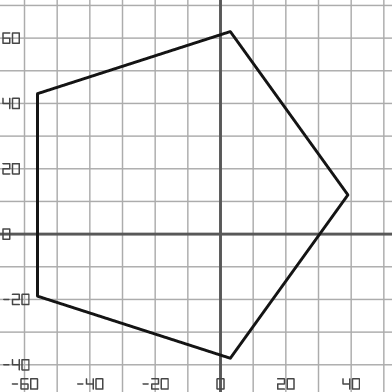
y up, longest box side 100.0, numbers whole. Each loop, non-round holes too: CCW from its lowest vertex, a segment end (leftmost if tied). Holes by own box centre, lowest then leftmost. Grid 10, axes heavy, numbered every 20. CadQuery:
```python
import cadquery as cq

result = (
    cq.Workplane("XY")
    .moveTo(3.0, -38.0)
    .lineTo(39.0, 12.0)
    .lineTo(3.0, 62.0)
    .lineTo(-56.0, 43.0)
    .lineTo(-56.0, -19.0)
    .close()
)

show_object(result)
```